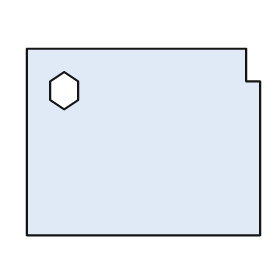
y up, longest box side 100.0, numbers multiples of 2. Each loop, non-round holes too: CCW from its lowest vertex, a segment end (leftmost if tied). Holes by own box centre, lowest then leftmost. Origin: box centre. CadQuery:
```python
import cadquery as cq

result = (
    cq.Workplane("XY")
    .moveTo(-50.0, -40.0)
    .lineTo(50.0, -40.0)
    .lineTo(50.0, 26.0)
    .lineTo(44.0, 26.0)
    .lineTo(44.0, 40.0)
    .lineTo(-50.0, 40.0)
    .close()
    .moveTo(-34.0, 14.0)
    .lineTo(-28.0, 18.0)
    .lineTo(-28.0, 26.0)
    .lineTo(-34.0, 30.0)
    .lineTo(-40.0, 26.0)
    .lineTo(-40.0, 18.0)
    .close()
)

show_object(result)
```